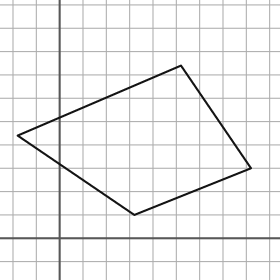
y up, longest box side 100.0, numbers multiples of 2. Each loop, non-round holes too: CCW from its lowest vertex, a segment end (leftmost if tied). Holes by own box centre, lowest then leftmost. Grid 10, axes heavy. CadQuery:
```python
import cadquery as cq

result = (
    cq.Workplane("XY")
    .moveTo(32.0, 10.0)
    .lineTo(82.0, 30.0)
    .lineTo(52.0, 74.0)
    .lineTo(-18.0, 44.0)
    .close()
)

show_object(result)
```